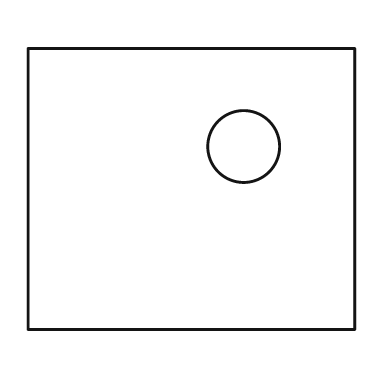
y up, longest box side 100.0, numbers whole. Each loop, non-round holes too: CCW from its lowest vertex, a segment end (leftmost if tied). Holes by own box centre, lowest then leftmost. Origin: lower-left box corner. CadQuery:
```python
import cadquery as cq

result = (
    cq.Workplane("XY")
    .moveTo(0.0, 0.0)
    .lineTo(100.0, 0.0)
    .lineTo(100.0, 86.0)
    .lineTo(0.0, 86.0)
    .close()
    .moveTo(66.0, 56.0)
    .circle(11.0)
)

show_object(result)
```